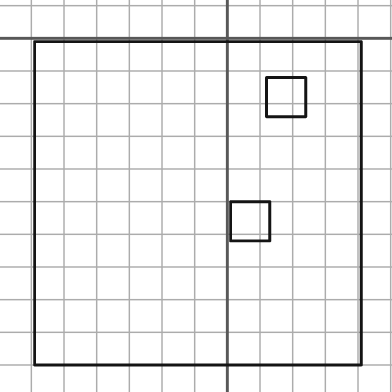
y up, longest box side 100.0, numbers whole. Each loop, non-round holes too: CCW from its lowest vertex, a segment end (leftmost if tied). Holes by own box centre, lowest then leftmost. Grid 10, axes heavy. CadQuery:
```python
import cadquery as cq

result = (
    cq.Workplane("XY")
    .moveTo(-59.0, -100.0)
    .lineTo(41.0, -100.0)
    .lineTo(41.0, -1.0)
    .lineTo(-59.0, -1.0)
    .close()
    .moveTo(1.0, -62.0)
    .lineTo(13.0, -62.0)
    .lineTo(13.0, -50.0)
    .lineTo(1.0, -50.0)
    .close()
    .moveTo(12.0, -24.0)
    .lineTo(24.0, -24.0)
    .lineTo(24.0, -12.0)
    .lineTo(12.0, -12.0)
    .close()
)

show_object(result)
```